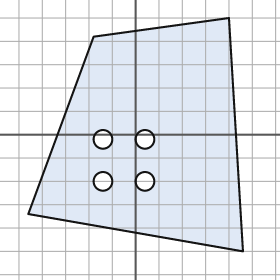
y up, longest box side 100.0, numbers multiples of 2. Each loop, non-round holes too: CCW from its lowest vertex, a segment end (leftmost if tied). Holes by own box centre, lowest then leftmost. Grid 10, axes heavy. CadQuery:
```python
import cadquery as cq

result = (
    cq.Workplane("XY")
    .moveTo(46.0, -50.0)
    .lineTo(40.0, 50.0)
    .lineTo(-18.0, 42.0)
    .lineTo(-46.0, -34.0)
    .close()
    .moveTo(-14.0, -20.0)
    .circle(4.0)
    .moveTo(4.0, -20.0)
    .circle(4.0)
    .moveTo(-14.0, -2.0)
    .circle(4.0)
    .moveTo(4.0, -2.0)
    .circle(4.0)
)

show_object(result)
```